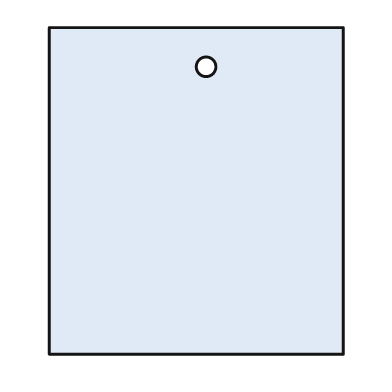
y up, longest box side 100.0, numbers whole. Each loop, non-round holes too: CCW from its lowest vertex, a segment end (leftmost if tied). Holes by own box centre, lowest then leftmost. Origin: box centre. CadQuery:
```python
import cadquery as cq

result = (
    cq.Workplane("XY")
    .moveTo(-45.0, -50.0)
    .lineTo(45.0, -50.0)
    .lineTo(45.0, 50.0)
    .lineTo(-45.0, 50.0)
    .close()
    .moveTo(3.0, 38.0)
    .circle(3.0)
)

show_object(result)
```